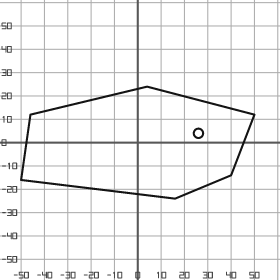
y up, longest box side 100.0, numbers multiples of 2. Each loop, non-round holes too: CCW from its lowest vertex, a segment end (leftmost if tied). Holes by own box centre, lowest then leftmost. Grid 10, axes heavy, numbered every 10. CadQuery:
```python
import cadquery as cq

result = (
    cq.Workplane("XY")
    .moveTo(16.0, -24.0)
    .lineTo(40.0, -14.0)
    .lineTo(50.0, 12.0)
    .lineTo(4.0, 24.0)
    .lineTo(-46.0, 12.0)
    .lineTo(-50.0, -16.0)
    .close()
    .moveTo(26.0, 4.0)
    .circle(2.0)
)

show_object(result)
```